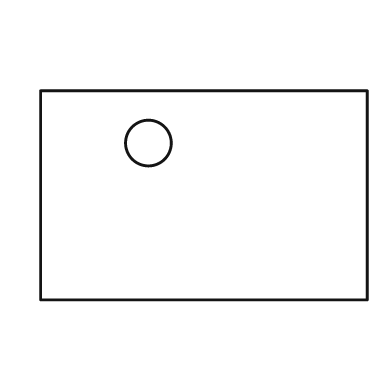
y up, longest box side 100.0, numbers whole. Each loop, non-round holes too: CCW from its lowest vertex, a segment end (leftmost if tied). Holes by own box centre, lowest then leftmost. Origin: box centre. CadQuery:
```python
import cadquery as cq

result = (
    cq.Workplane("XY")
    .moveTo(-50.0, -32.0)
    .lineTo(50.0, -32.0)
    .lineTo(50.0, 32.0)
    .lineTo(-50.0, 32.0)
    .close()
    .moveTo(-17.0, 16.0)
    .circle(7.0)
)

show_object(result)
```